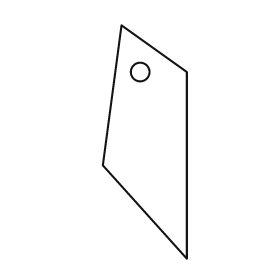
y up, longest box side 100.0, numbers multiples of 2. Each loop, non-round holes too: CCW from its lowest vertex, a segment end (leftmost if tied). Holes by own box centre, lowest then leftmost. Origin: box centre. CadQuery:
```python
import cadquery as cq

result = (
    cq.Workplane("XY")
    .moveTo(18.0, -50.0)
    .lineTo(18.0, 30.0)
    .lineTo(-10.0, 50.0)
    .lineTo(-18.0, -10.0)
    .close()
    .moveTo(-2.0, 30.0)
    .circle(4.0)
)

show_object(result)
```